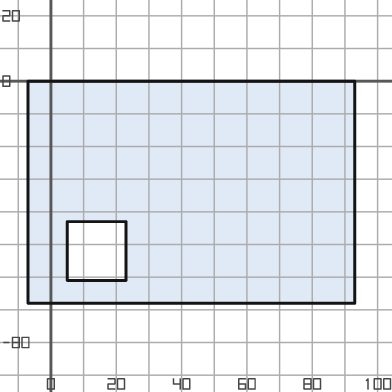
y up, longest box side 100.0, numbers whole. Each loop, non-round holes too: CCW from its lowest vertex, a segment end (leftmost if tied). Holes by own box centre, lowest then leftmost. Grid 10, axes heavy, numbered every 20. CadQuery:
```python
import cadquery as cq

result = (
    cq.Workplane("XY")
    .moveTo(-7.0, -68.0)
    .lineTo(93.0, -68.0)
    .lineTo(93.0, 0.0)
    .lineTo(-7.0, 0.0)
    .close()
    .moveTo(5.0, -61.0)
    .lineTo(23.0, -61.0)
    .lineTo(23.0, -43.0)
    .lineTo(5.0, -43.0)
    .close()
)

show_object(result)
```